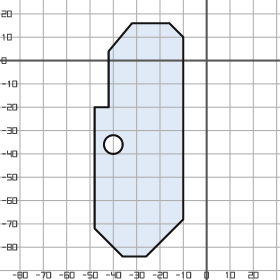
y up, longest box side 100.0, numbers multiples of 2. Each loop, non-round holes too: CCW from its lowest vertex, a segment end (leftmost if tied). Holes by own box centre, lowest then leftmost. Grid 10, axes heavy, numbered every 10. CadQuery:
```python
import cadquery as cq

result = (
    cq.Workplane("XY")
    .moveTo(-36.0, -84.0)
    .lineTo(-26.0, -84.0)
    .lineTo(-10.0, -68.0)
    .lineTo(-10.0, 10.0)
    .lineTo(-16.0, 16.0)
    .lineTo(-32.0, 16.0)
    .lineTo(-42.0, 4.0)
    .lineTo(-42.0, -20.0)
    .lineTo(-48.0, -20.0)
    .lineTo(-48.0, -72.0)
    .close()
    .moveTo(-40.0, -36.0)
    .circle(4.0)
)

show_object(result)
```